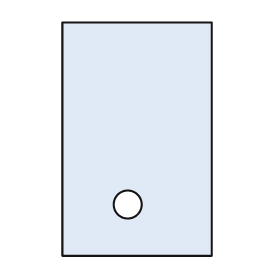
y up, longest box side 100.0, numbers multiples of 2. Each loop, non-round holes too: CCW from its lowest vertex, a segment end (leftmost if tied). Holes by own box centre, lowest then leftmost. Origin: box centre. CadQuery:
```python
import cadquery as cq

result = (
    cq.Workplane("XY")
    .moveTo(-32.0, -50.0)
    .lineTo(32.0, -50.0)
    .lineTo(32.0, 50.0)
    .lineTo(-32.0, 50.0)
    .close()
    .moveTo(-4.0, -28.0)
    .circle(6.0)
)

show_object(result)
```